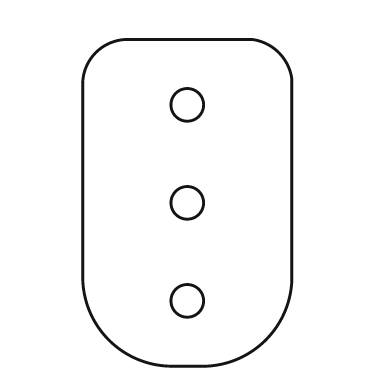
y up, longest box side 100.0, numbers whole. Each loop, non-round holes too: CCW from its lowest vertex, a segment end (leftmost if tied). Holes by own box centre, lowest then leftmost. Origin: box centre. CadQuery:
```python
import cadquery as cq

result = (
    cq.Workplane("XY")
    .moveTo(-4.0, -50.0)
    .lineTo(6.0, -50.0)
    .threePointArc((24.0, -42.0), (32.0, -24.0))
    .lineTo(32.0, 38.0)
    .threePointArc((28.0, 46.0), (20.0, 50.0))
    .lineTo(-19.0, 50.0)
    .threePointArc((-28.0, 46.0), (-32.0, 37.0))
    .lineTo(-32.0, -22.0)
    .threePointArc((-24.0, -42.0), (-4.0, -50.0))
    .close()
    .moveTo(0.0, -30.0)
    .circle(5.0)
    .moveTo(0.0, 0.0)
    .circle(5.0)
    .moveTo(0.0, 30.0)
    .circle(5.0)
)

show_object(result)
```